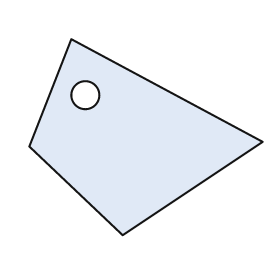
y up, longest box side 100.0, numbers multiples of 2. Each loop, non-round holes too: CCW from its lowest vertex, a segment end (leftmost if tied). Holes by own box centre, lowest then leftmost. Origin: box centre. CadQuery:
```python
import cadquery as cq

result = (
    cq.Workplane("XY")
    .moveTo(-10.0, -42.0)
    .lineTo(50.0, -2.0)
    .lineTo(-32.0, 42.0)
    .lineTo(-50.0, -4.0)
    .close()
    .moveTo(-26.0, 18.0)
    .circle(6.0)
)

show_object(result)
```